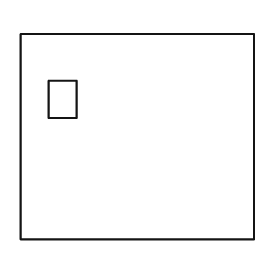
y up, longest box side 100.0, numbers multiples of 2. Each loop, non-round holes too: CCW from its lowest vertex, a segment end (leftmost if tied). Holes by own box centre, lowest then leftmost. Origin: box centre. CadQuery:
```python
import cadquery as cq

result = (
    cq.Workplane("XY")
    .moveTo(-50.0, -44.0)
    .lineTo(50.0, -44.0)
    .lineTo(50.0, 44.0)
    .lineTo(-50.0, 44.0)
    .close()
    .moveTo(-38.0, 8.0)
    .lineTo(-26.0, 8.0)
    .lineTo(-26.0, 24.0)
    .lineTo(-38.0, 24.0)
    .close()
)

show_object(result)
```